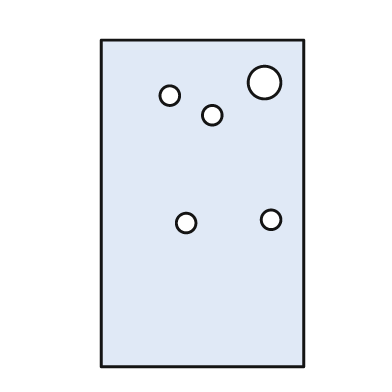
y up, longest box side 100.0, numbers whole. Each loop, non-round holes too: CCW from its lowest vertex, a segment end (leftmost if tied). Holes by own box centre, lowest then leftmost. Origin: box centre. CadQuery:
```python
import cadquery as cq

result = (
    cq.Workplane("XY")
    .moveTo(-31.0, -50.0)
    .lineTo(31.0, -50.0)
    .lineTo(31.0, 50.0)
    .lineTo(-31.0, 50.0)
    .close()
    .moveTo(-5.0, -6.0)
    .circle(3.0)
    .moveTo(21.0, -5.0)
    .circle(3.0)
    .moveTo(3.0, 27.0)
    .circle(3.0)
    .moveTo(-10.0, 33.0)
    .circle(3.0)
    .moveTo(19.0, 37.0)
    .circle(5.0)
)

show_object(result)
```